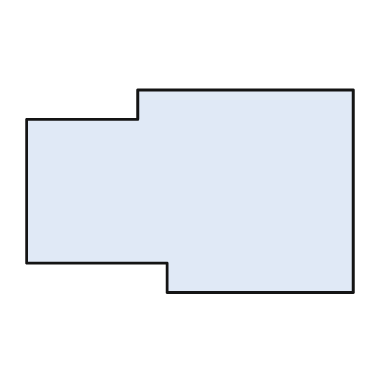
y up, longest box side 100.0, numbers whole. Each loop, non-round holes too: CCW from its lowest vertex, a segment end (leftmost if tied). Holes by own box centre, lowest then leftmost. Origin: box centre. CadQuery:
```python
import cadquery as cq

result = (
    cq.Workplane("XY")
    .moveTo(-7.0, -31.0)
    .lineTo(50.0, -31.0)
    .lineTo(50.0, 31.0)
    .lineTo(-16.0, 31.0)
    .lineTo(-16.0, 22.0)
    .lineTo(-50.0, 22.0)
    .lineTo(-50.0, -22.0)
    .lineTo(-7.0, -22.0)
    .close()
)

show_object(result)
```